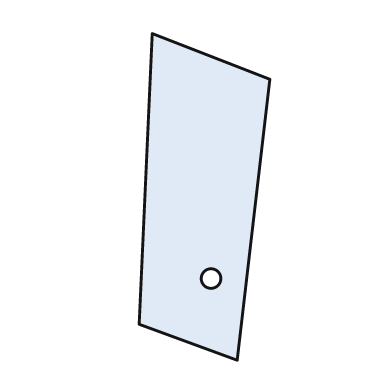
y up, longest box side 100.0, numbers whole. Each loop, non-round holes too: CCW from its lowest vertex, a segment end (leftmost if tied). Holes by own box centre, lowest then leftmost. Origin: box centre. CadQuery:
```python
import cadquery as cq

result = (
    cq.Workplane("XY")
    .moveTo(10.0, -50.0)
    .lineTo(20.0, 36.0)
    .lineTo(-16.0, 50.0)
    .lineTo(-20.0, -39.0)
    .close()
    .moveTo(2.0, -25.0)
    .circle(3.0)
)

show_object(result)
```